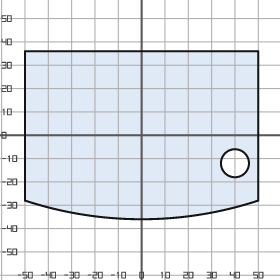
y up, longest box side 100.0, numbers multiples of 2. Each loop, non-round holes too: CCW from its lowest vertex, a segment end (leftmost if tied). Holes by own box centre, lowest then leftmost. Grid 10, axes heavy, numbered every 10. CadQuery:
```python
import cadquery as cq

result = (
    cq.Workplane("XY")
    .moveTo(-50.0, -28.0)
    .threePointArc((0.0, -36.0), (50.0, -28.0))
    .lineTo(50.0, 36.0)
    .lineTo(-50.0, 36.0)
    .close()
    .moveTo(40.0, -12.0)
    .circle(6.0)
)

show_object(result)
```